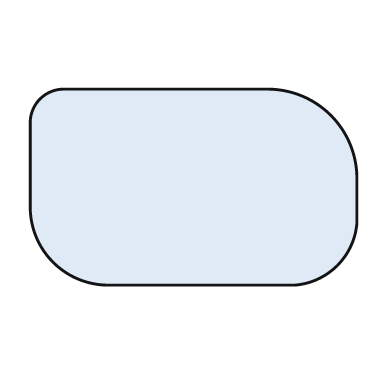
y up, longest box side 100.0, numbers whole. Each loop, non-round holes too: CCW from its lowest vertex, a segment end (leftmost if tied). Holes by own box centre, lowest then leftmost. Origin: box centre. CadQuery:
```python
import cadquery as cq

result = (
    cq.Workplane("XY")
    .moveTo(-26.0, -30.0)
    .lineTo(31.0, -30.0)
    .threePointArc((44.0, -24.0), (50.0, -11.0))
    .lineTo(50.0, 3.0)
    .threePointArc((42.0, 22.0), (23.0, 30.0))
    .lineTo(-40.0, 30.0)
    .threePointArc((-47.0, 27.0), (-50.0, 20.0))
    .lineTo(-50.0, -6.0)
    .threePointArc((-43.0, -23.0), (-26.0, -30.0))
    .close()
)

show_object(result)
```